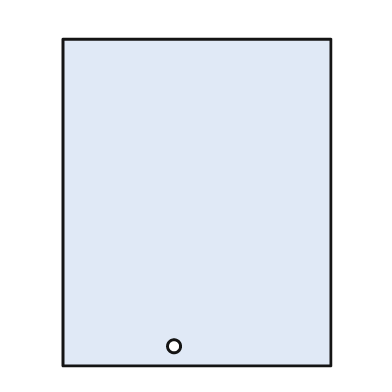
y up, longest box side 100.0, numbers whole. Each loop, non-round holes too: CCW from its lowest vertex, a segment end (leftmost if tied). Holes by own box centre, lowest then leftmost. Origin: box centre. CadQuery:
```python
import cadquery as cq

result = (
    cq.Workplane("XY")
    .moveTo(-41.0, -50.0)
    .lineTo(41.0, -50.0)
    .lineTo(41.0, 50.0)
    .lineTo(-41.0, 50.0)
    .close()
    .moveTo(-7.0, -44.0)
    .circle(2.0)
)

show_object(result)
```